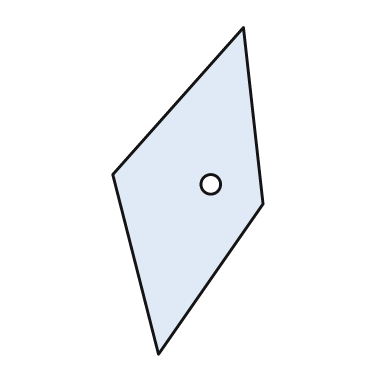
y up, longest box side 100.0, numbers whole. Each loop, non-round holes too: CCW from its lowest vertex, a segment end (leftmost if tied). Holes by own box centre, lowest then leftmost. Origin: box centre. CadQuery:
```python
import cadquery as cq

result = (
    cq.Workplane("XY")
    .moveTo(-9.0, -50.0)
    .lineTo(23.0, -4.0)
    .lineTo(17.0, 50.0)
    .lineTo(-23.0, 5.0)
    .close()
    .moveTo(7.0, 2.0)
    .circle(3.0)
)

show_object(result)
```